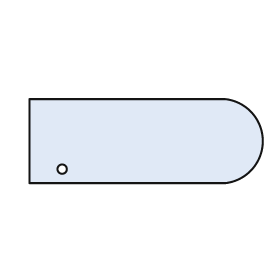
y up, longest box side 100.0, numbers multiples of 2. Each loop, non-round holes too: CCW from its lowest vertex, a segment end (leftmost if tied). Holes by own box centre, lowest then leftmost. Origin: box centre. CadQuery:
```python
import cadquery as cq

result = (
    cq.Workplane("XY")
    .moveTo(-50.0, -18.0)
    .lineTo(34.0, -18.0)
    .threePointArc((50.0, 0.0), (34.0, 18.0))
    .lineTo(-50.0, 18.0)
    .close()
    .moveTo(-36.0, -12.0)
    .circle(2.0)
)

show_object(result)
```